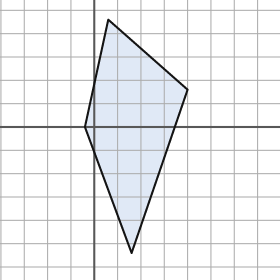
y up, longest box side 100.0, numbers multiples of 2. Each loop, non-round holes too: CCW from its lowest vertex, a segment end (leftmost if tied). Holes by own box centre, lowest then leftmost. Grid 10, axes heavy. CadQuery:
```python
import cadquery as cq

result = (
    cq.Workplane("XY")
    .moveTo(16.0, -54.0)
    .lineTo(40.0, 16.0)
    .lineTo(6.0, 46.0)
    .lineTo(-4.0, 0.0)
    .close()
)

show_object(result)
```